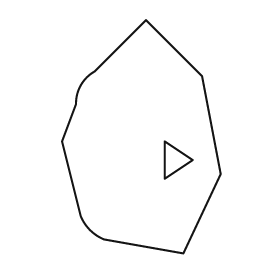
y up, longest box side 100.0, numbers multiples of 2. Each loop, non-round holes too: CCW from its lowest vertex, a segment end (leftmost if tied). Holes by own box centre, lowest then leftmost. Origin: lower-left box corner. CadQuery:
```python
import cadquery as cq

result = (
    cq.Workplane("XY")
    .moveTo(52.0, 0.0)
    .lineTo(68.0, 34.0)
    .lineTo(60.0, 76.0)
    .lineTo(36.0, 100.0)
    .lineTo(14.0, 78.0)
    .threePointArc((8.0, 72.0), (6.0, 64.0))
    .lineTo(0.0, 48.0)
    .lineTo(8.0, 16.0)
    .threePointArc((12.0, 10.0), (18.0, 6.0))
    .close()
    .moveTo(44.0, 32.0)
    .lineTo(56.0, 40.0)
    .lineTo(44.0, 48.0)
    .close()
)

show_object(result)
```